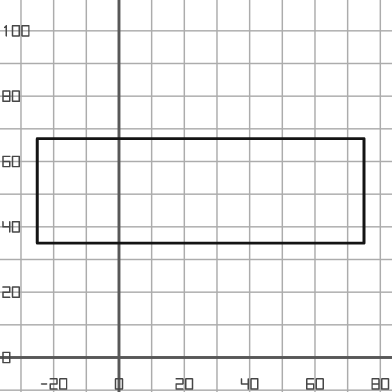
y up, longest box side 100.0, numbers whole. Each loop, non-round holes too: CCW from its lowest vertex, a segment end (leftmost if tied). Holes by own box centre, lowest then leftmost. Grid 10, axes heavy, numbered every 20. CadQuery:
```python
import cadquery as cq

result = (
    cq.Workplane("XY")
    .moveTo(-25.0, 35.0)
    .lineTo(75.0, 35.0)
    .lineTo(75.0, 67.0)
    .lineTo(-25.0, 67.0)
    .close()
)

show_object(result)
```